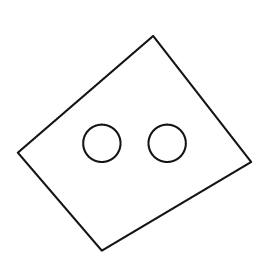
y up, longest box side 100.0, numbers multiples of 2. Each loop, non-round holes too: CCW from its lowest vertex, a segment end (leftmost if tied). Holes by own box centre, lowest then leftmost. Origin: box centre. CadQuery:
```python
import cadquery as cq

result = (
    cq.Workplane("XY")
    .moveTo(-14.0, -46.0)
    .lineTo(50.0, -8.0)
    .lineTo(8.0, 46.0)
    .lineTo(-50.0, -4.0)
    .close()
    .moveTo(-14.0, 0.0)
    .circle(8.0)
    .moveTo(14.0, 0.0)
    .circle(8.0)
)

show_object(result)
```